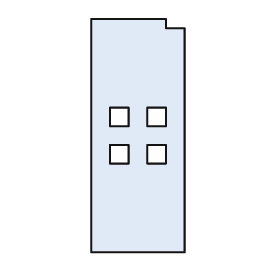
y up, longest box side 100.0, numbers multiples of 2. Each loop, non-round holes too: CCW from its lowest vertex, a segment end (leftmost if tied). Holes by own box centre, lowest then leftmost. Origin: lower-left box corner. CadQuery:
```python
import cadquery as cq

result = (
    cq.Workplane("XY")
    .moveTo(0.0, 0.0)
    .lineTo(40.0, 0.0)
    .lineTo(40.0, 96.0)
    .lineTo(32.0, 96.0)
    .lineTo(32.0, 100.0)
    .lineTo(0.0, 100.0)
    .close()
    .moveTo(8.0, 38.0)
    .lineTo(16.0, 38.0)
    .lineTo(16.0, 46.0)
    .lineTo(8.0, 46.0)
    .close()
    .moveTo(24.0, 38.0)
    .lineTo(32.0, 38.0)
    .lineTo(32.0, 46.0)
    .lineTo(24.0, 46.0)
    .close()
    .moveTo(8.0, 54.0)
    .lineTo(16.0, 54.0)
    .lineTo(16.0, 62.0)
    .lineTo(8.0, 62.0)
    .close()
    .moveTo(24.0, 54.0)
    .lineTo(32.0, 54.0)
    .lineTo(32.0, 62.0)
    .lineTo(24.0, 62.0)
    .close()
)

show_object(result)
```